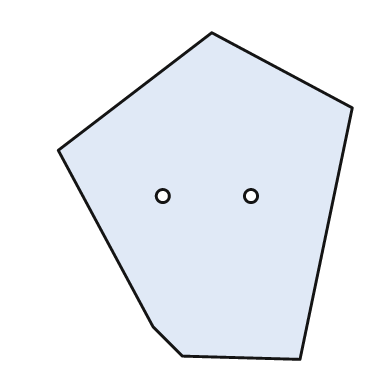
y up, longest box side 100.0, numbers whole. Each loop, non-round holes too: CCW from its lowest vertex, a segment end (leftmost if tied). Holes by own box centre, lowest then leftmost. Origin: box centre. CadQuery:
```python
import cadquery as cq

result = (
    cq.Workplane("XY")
    .moveTo(29.0, -50.0)
    .lineTo(45.0, 27.0)
    .lineTo(2.0, 50.0)
    .lineTo(-45.0, 14.0)
    .lineTo(-16.0, -40.0)
    .lineTo(-7.0, -49.0)
    .close()
    .moveTo(-13.0, 0.0)
    .circle(2.0)
    .moveTo(14.0, 0.0)
    .circle(2.0)
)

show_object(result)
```